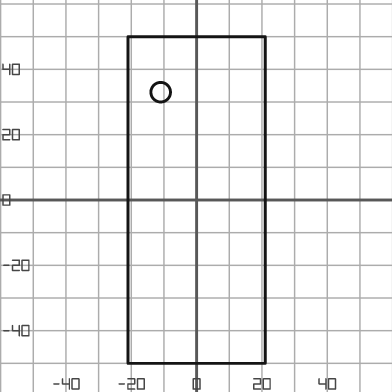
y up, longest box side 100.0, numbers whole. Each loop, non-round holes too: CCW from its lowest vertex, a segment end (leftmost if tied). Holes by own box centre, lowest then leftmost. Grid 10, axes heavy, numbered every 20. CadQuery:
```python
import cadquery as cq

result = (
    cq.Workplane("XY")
    .moveTo(-21.0, -50.0)
    .lineTo(21.0, -50.0)
    .lineTo(21.0, 50.0)
    .lineTo(-21.0, 50.0)
    .close()
    .moveTo(-11.0, 33.0)
    .circle(3.0)
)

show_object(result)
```